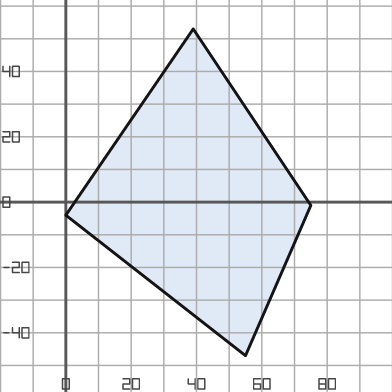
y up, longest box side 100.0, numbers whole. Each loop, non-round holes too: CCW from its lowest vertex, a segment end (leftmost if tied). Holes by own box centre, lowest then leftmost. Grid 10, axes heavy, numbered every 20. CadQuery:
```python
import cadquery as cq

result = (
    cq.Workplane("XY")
    .moveTo(55.0, -47.0)
    .lineTo(75.0, -1.0)
    .lineTo(39.0, 53.0)
    .lineTo(0.0, -4.0)
    .close()
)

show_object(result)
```